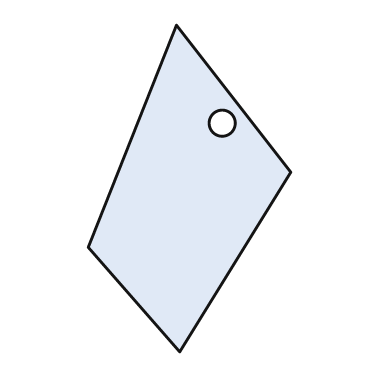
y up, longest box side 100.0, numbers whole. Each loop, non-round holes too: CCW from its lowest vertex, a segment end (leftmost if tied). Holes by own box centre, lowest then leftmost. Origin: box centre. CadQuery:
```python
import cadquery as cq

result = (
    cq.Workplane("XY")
    .moveTo(-3.0, -50.0)
    .lineTo(31.0, 5.0)
    .lineTo(-4.0, 50.0)
    .lineTo(-31.0, -18.0)
    .close()
    .moveTo(10.0, 20.0)
    .circle(4.0)
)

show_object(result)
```